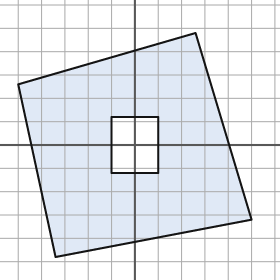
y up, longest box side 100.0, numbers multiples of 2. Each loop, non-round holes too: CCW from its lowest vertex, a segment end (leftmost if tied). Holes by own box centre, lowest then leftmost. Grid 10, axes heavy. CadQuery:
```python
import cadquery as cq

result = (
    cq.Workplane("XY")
    .moveTo(-34.0, -48.0)
    .lineTo(50.0, -32.0)
    .lineTo(26.0, 48.0)
    .lineTo(-50.0, 26.0)
    .close()
    .moveTo(-10.0, -12.0)
    .lineTo(10.0, -12.0)
    .lineTo(10.0, 12.0)
    .lineTo(-10.0, 12.0)
    .close()
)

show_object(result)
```